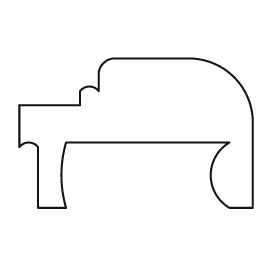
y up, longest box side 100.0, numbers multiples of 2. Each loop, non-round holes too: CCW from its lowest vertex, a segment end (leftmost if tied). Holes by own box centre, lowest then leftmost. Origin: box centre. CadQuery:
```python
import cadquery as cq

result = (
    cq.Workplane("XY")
    .moveTo(-42.0, -32.0)
    .lineTo(-30.0, -32.0)
    .threePointArc((-32.0, -18.0), (-30.0, -4.0))
    .lineTo(40.0, -4.0)
    .threePointArc((32.0, -18.0), (40.0, -32.0))
    .lineTo(50.0, -32.0)
    .lineTo(50.0, 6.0)
    .threePointArc((42.0, 24.0), (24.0, 32.0))
    .lineTo(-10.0, 32.0)
    .threePointArc((-14.0, 30.0), (-16.0, 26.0))
    .lineTo(-16.0, 18.0)
    .threePointArc((-20.0, 20.0), (-24.0, 18.0))
    .lineTo(-24.0, 12.0)
    .lineTo(-50.0, 12.0)
    .lineTo(-50.0, -6.0)
    .threePointArc((-46.0, -4.0), (-42.0, -6.0))
    .close()
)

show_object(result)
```